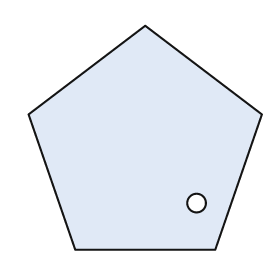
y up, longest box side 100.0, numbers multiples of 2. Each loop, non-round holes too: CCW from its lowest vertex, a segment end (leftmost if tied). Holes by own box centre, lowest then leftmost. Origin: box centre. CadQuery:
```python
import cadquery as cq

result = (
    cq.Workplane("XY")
    .moveTo(-30.0, -48.0)
    .lineTo(30.0, -48.0)
    .lineTo(50.0, 10.0)
    .lineTo(0.0, 48.0)
    .lineTo(-50.0, 10.0)
    .close()
    .moveTo(22.0, -28.0)
    .circle(4.0)
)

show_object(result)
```